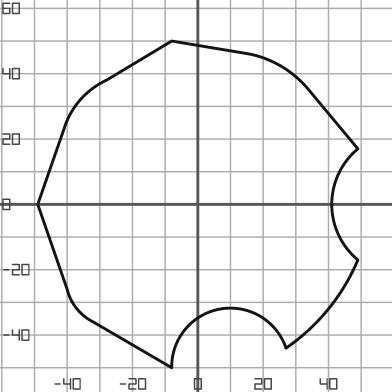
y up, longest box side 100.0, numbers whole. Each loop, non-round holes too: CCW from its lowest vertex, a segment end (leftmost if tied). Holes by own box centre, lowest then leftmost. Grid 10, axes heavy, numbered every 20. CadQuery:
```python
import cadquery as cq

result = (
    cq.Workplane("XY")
    .moveTo(-8.0, -50.0)
    .threePointArc((7.0, -32.0), (27.0, -44.0))
    .threePointArc((40.0, -32.0), (49.0, -17.0))
    .threePointArc((41.0, 0.0), (49.0, 17.0))
    .lineTo(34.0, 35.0)
    .threePointArc((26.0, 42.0), (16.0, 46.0))
    .lineTo(-8.0, 50.0)
    .lineTo(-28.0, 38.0)
    .threePointArc((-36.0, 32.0), (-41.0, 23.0))
    .lineTo(-49.0, 0.0)
    .lineTo(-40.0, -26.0)
    .threePointArc((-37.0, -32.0), (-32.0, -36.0))
    .close()
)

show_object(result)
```